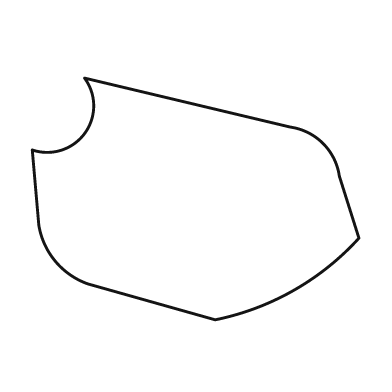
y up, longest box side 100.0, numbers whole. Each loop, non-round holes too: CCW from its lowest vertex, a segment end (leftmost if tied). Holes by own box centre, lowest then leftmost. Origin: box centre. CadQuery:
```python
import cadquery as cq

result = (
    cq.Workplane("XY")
    .moveTo(6.0, -37.0)
    .threePointArc((30.0, -28.0), (50.0, -12.0))
    .lineTo(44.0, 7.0)
    .threePointArc((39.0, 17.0), (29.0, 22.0))
    .lineTo(-34.0, 37.0)
    .threePointArc((-34.0, 20.0), (-50.0, 15.0))
    .lineTo(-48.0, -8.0)
    .threePointArc((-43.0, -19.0), (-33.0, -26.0))
    .close()
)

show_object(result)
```